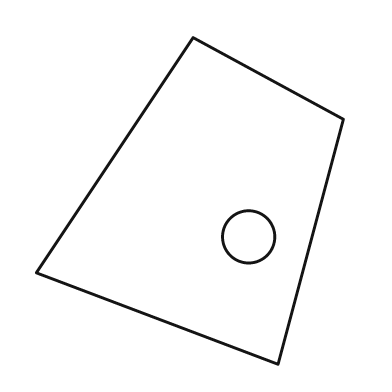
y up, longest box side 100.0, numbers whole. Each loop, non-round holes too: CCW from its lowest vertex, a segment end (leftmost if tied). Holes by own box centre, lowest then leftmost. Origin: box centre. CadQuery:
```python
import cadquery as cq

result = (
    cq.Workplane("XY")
    .moveTo(27.0, -50.0)
    .lineTo(47.0, 25.0)
    .lineTo(1.0, 50.0)
    .lineTo(-47.0, -22.0)
    .close()
    .moveTo(18.0, -11.0)
    .circle(8.0)
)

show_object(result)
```